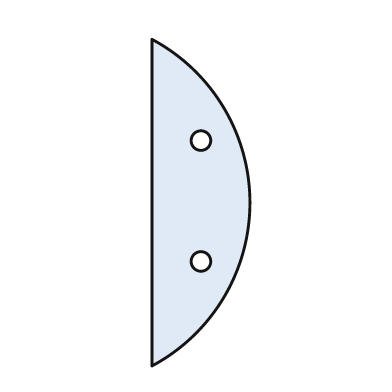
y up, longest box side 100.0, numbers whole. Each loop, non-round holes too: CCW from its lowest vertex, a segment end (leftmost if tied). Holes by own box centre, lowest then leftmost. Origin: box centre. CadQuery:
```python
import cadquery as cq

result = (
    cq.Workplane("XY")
    .moveTo(-15.0, -50.0)
    .threePointArc((15.0, 0.0), (-15.0, 50.0))
    .close()
    .moveTo(0.0, -18.0)
    .circle(3.0)
    .moveTo(0.0, 19.0)
    .circle(3.0)
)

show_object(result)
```